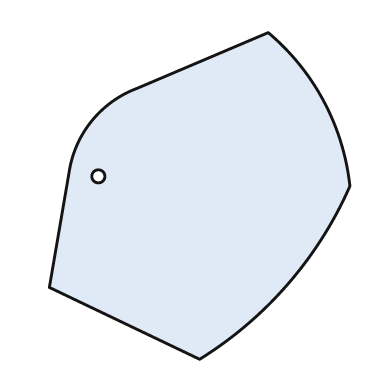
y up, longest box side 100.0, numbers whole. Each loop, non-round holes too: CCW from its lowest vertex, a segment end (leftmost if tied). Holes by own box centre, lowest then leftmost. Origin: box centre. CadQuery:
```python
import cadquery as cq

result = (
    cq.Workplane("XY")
    .moveTo(0.0, -50.0)
    .threePointArc((27.0, -27.0), (46.0, 3.0))
    .threePointArc((38.0, 29.0), (21.0, 50.0))
    .lineTo(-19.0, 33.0)
    .threePointArc((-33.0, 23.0), (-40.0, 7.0))
    .lineTo(-46.0, -28.0)
    .close()
    .moveTo(-31.0, 6.0)
    .circle(2.0)
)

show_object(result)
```